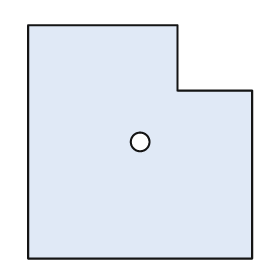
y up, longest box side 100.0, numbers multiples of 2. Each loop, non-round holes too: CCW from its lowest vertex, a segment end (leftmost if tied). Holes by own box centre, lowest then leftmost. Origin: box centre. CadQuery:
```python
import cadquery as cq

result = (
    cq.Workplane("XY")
    .moveTo(-48.0, -50.0)
    .lineTo(48.0, -50.0)
    .lineTo(48.0, 22.0)
    .lineTo(16.0, 22.0)
    .lineTo(16.0, 50.0)
    .lineTo(-48.0, 50.0)
    .close()
    .moveTo(0.0, 0.0)
    .circle(4.0)
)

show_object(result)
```